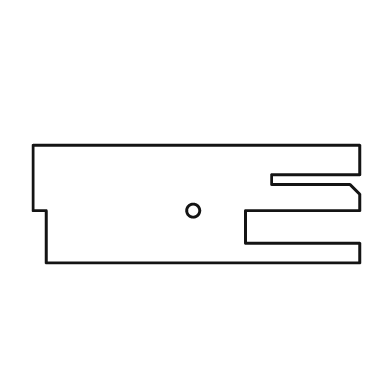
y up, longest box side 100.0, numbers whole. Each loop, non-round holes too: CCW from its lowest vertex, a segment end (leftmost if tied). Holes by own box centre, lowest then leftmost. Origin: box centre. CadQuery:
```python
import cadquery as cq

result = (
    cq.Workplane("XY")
    .moveTo(-46.0, -18.0)
    .lineTo(50.0, -18.0)
    .lineTo(50.0, -12.0)
    .lineTo(15.0, -12.0)
    .lineTo(15.0, -2.0)
    .lineTo(50.0, -2.0)
    .lineTo(50.0, 3.0)
    .lineTo(47.0, 6.0)
    .lineTo(23.0, 6.0)
    .lineTo(23.0, 9.0)
    .lineTo(50.0, 9.0)
    .lineTo(50.0, 18.0)
    .lineTo(-50.0, 18.0)
    .lineTo(-50.0, -2.0)
    .lineTo(-46.0, -2.0)
    .close()
    .moveTo(-1.0, -2.0)
    .circle(2.0)
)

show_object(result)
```